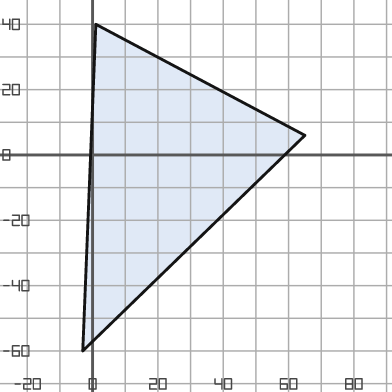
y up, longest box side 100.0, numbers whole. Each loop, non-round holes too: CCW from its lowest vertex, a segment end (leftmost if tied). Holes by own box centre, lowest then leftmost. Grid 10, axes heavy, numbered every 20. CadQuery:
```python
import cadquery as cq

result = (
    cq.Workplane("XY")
    .moveTo(-3.0, -60.0)
    .lineTo(65.0, 6.0)
    .lineTo(1.0, 40.0)
    .close()
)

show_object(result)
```